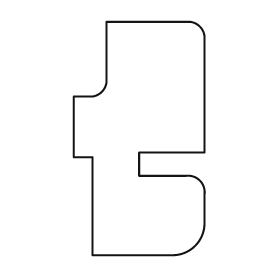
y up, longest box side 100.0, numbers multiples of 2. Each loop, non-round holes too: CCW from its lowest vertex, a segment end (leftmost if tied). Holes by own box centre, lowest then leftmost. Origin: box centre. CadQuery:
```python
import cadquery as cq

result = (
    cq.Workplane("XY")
    .moveTo(-20.0, -50.0)
    .lineTo(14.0, -50.0)
    .threePointArc((24.0, -46.0), (28.0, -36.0))
    .lineTo(28.0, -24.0)
    .threePointArc((26.0, -18.0), (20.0, -16.0))
    .lineTo(0.0, -16.0)
    .lineTo(0.0, -6.0)
    .lineTo(28.0, -6.0)
    .lineTo(28.0, 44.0)
    .threePointArc((26.0, 48.0), (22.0, 50.0))
    .lineTo(-14.0, 50.0)
    .lineTo(-14.0, 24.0)
    .threePointArc((-16.0, 20.0), (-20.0, 18.0))
    .lineTo(-28.0, 18.0)
    .lineTo(-28.0, -8.0)
    .lineTo(-20.0, -8.0)
    .close()
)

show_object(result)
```